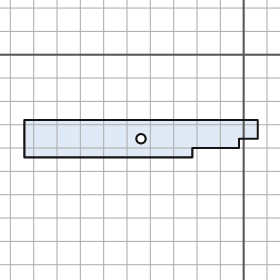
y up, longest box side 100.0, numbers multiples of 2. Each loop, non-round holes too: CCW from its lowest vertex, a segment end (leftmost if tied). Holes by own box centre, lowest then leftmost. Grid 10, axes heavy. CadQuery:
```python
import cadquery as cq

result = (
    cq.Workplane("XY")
    .moveTo(-94.0, -44.0)
    .lineTo(-22.0, -44.0)
    .lineTo(-22.0, -40.0)
    .lineTo(-2.0, -40.0)
    .lineTo(-2.0, -36.0)
    .lineTo(6.0, -36.0)
    .lineTo(6.0, -28.0)
    .lineTo(-94.0, -28.0)
    .close()
    .moveTo(-44.0, -36.0)
    .circle(2.0)
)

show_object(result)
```